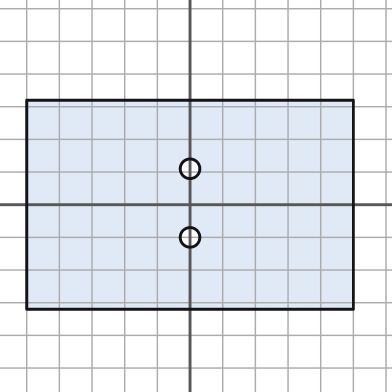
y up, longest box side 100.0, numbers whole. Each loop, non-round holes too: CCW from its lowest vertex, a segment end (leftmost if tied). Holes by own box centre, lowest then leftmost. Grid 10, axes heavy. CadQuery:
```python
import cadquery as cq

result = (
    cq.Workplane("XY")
    .moveTo(-50.0, -32.0)
    .lineTo(50.0, -32.0)
    .lineTo(50.0, 32.0)
    .lineTo(-50.0, 32.0)
    .close()
    .moveTo(0.0, -10.0)
    .circle(3.0)
    .moveTo(0.0, 11.0)
    .circle(3.0)
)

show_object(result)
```